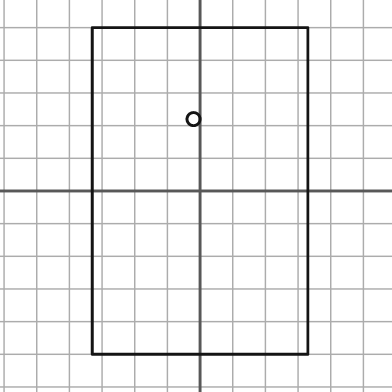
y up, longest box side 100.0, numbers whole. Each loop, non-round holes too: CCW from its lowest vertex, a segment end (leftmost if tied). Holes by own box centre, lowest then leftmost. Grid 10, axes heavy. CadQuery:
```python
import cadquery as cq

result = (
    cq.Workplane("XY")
    .moveTo(-33.0, -50.0)
    .lineTo(33.0, -50.0)
    .lineTo(33.0, 50.0)
    .lineTo(-33.0, 50.0)
    .close()
    .moveTo(-2.0, 22.0)
    .circle(2.0)
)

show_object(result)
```